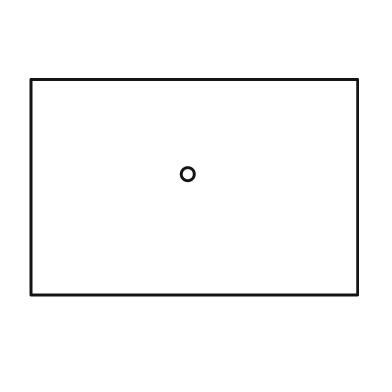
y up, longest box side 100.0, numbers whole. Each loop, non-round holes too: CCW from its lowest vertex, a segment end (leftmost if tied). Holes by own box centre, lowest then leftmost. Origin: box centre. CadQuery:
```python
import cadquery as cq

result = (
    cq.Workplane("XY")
    .moveTo(-50.0, -33.0)
    .lineTo(50.0, -33.0)
    .lineTo(50.0, 33.0)
    .lineTo(-50.0, 33.0)
    .close()
    .moveTo(-2.0, 4.0)
    .circle(2.0)
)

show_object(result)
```